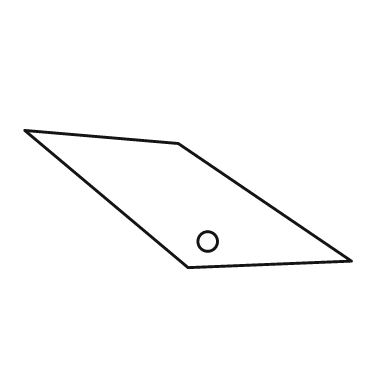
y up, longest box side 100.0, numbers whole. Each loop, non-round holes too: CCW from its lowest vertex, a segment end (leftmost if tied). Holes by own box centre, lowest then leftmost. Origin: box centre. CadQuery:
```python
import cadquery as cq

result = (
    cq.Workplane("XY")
    .moveTo(0.0, -21.0)
    .lineTo(50.0, -19.0)
    .lineTo(-3.0, 17.0)
    .lineTo(-50.0, 21.0)
    .close()
    .moveTo(6.0, -13.0)
    .circle(3.0)
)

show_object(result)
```